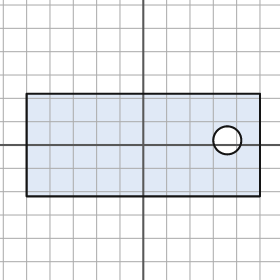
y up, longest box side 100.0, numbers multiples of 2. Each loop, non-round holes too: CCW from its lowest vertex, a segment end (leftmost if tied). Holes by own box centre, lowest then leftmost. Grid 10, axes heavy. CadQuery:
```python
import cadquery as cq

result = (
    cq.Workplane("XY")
    .moveTo(-50.0, -22.0)
    .lineTo(50.0, -22.0)
    .lineTo(50.0, 22.0)
    .lineTo(-50.0, 22.0)
    .close()
    .moveTo(36.0, 2.0)
    .circle(6.0)
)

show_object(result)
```